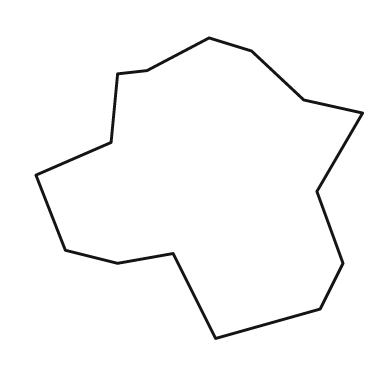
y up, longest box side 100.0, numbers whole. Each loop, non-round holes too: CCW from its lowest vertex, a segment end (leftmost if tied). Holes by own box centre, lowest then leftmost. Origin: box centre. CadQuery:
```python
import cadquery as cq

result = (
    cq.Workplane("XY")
    .moveTo(5.0, -46.0)
    .lineTo(37.0, -37.0)
    .lineTo(44.0, -23.0)
    .lineTo(36.0, -1.0)
    .lineTo(50.0, 23.0)
    .lineTo(32.0, 27.0)
    .lineTo(16.0, 42.0)
    .lineTo(3.0, 46.0)
    .lineTo(-16.0, 36.0)
    .lineTo(-25.0, 35.0)
    .lineTo(-27.0, 14.0)
    .lineTo(-50.0, 4.0)
    .lineTo(-41.0, -19.0)
    .lineTo(-25.0, -23.0)
    .lineTo(-8.0, -20.0)
    .close()
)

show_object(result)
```